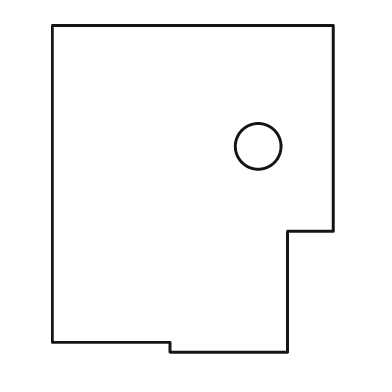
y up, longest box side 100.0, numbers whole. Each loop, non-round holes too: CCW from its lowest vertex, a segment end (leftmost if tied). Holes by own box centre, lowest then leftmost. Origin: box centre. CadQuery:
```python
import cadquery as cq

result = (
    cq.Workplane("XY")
    .moveTo(-7.0, -50.0)
    .lineTo(29.0, -50.0)
    .lineTo(29.0, -13.0)
    .lineTo(43.0, -13.0)
    .lineTo(43.0, 50.0)
    .lineTo(-43.0, 50.0)
    .lineTo(-43.0, -47.0)
    .lineTo(-7.0, -47.0)
    .close()
    .moveTo(20.0, 13.0)
    .circle(7.0)
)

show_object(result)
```